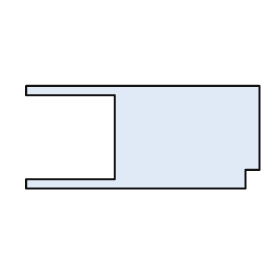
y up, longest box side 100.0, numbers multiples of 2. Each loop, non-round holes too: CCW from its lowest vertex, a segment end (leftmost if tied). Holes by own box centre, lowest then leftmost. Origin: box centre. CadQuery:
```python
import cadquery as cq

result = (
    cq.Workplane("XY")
    .moveTo(-50.0, -22.0)
    .lineTo(44.0, -22.0)
    .lineTo(44.0, -14.0)
    .lineTo(50.0, -14.0)
    .lineTo(50.0, 22.0)
    .lineTo(-50.0, 22.0)
    .lineTo(-50.0, 18.0)
    .lineTo(-12.0, 18.0)
    .lineTo(-12.0, -18.0)
    .lineTo(-50.0, -18.0)
    .close()
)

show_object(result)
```